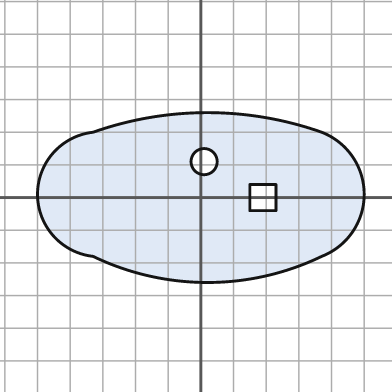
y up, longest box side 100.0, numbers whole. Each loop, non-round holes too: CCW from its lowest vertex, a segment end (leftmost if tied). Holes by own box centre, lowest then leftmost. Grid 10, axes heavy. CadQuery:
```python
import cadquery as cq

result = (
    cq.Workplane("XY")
    .moveTo(-33.0, -18.0)
    .threePointArc((2.0, -26.0), (37.0, -18.0))
    .threePointArc((50.0, 1.0), (37.0, 20.0))
    .threePointArc((2.0, 26.0), (-33.0, 20.0))
    .threePointArc((-50.0, 1.0), (-33.0, -18.0))
    .close()
    .moveTo(15.0, -4.0)
    .lineTo(23.0, -4.0)
    .lineTo(23.0, 4.0)
    .lineTo(15.0, 4.0)
    .close()
    .moveTo(1.0, 11.0)
    .circle(4.0)
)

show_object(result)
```